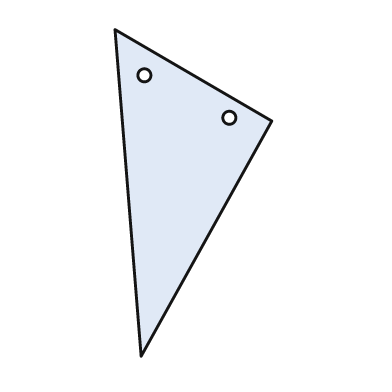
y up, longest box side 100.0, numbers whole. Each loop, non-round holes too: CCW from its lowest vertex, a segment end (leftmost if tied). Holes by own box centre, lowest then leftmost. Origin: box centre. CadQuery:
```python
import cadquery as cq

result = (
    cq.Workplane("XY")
    .moveTo(-16.0, -50.0)
    .lineTo(24.0, 22.0)
    .lineTo(-24.0, 50.0)
    .close()
    .moveTo(11.0, 23.0)
    .circle(2.0)
    .moveTo(-15.0, 36.0)
    .circle(2.0)
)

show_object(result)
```